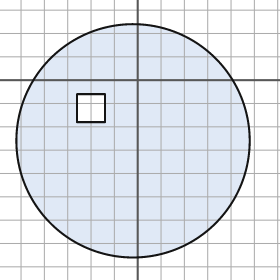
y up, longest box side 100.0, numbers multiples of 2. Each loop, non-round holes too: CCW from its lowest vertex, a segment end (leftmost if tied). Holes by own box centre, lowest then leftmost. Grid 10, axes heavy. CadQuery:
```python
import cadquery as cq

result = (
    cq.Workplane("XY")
    .moveTo(-2.0, -26.0)
    .circle(50.0)
    .moveTo(-26.0, -18.0)
    .lineTo(-14.0, -18.0)
    .lineTo(-14.0, -6.0)
    .lineTo(-26.0, -6.0)
    .close()
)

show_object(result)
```